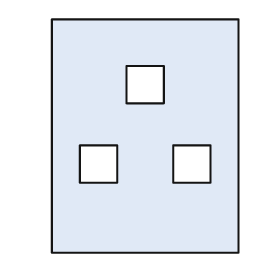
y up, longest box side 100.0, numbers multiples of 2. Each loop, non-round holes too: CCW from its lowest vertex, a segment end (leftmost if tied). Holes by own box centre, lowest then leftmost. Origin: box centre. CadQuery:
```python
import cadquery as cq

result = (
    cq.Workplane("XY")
    .moveTo(-40.0, -50.0)
    .lineTo(40.0, -50.0)
    .lineTo(40.0, 50.0)
    .lineTo(-40.0, 50.0)
    .close()
    .moveTo(-28.0, -20.0)
    .lineTo(-12.0, -20.0)
    .lineTo(-12.0, -4.0)
    .lineTo(-28.0, -4.0)
    .close()
    .moveTo(12.0, -20.0)
    .lineTo(28.0, -20.0)
    .lineTo(28.0, -4.0)
    .lineTo(12.0, -4.0)
    .close()
    .moveTo(-8.0, 14.0)
    .lineTo(8.0, 14.0)
    .lineTo(8.0, 30.0)
    .lineTo(-8.0, 30.0)
    .close()
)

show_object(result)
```